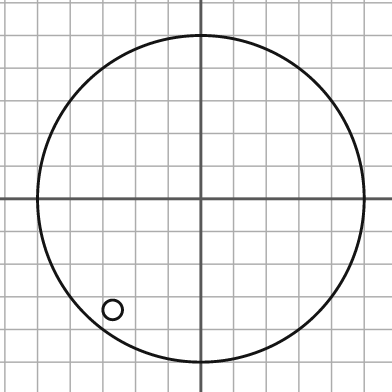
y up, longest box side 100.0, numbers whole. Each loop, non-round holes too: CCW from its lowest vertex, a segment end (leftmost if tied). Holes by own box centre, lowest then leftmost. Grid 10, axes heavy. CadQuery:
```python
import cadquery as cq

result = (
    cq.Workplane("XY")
    .moveTo(0.0, 0.0)
    .circle(50.0)
    .moveTo(-27.0, -34.0)
    .circle(3.0)
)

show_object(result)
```